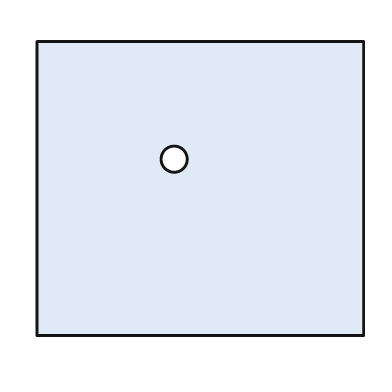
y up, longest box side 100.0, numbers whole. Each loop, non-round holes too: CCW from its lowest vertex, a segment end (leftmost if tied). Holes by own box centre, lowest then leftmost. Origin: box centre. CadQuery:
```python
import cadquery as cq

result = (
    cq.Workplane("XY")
    .moveTo(-50.0, -45.0)
    .lineTo(50.0, -45.0)
    .lineTo(50.0, 45.0)
    .lineTo(-50.0, 45.0)
    .close()
    .moveTo(-8.0, 9.0)
    .circle(4.0)
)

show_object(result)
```